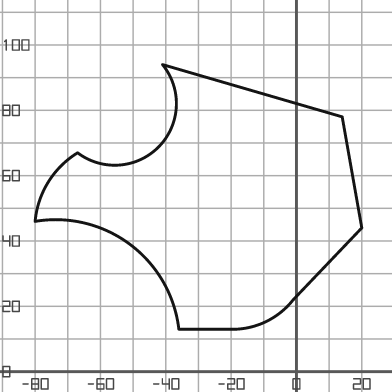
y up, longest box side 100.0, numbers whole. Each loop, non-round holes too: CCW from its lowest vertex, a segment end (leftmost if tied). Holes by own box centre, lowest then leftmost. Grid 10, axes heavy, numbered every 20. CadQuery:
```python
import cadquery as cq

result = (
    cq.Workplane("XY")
    .moveTo(-36.0, 13.0)
    .lineTo(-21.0, 13.0)
    .threePointArc((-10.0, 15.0), (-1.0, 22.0))
    .lineTo(20.0, 44.0)
    .lineTo(14.0, 78.0)
    .lineTo(-41.0, 94.0)
    .threePointArc((-42.0, 69.0), (-67.0, 67.0))
    .threePointArc((-76.0, 58.0), (-80.0, 46.0))
    .threePointArc((-51.0, 39.0), (-36.0, 13.0))
    .close()
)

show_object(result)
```